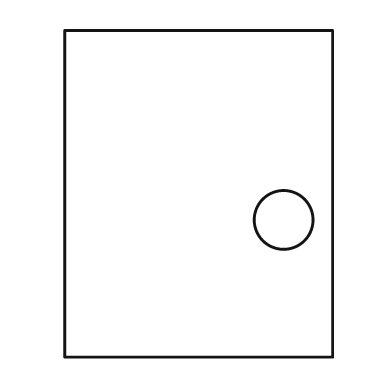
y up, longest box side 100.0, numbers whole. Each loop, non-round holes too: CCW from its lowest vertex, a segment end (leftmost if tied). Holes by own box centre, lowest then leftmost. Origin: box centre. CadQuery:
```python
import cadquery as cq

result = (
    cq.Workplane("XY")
    .moveTo(-41.0, -50.0)
    .lineTo(41.0, -50.0)
    .lineTo(41.0, 50.0)
    .lineTo(-41.0, 50.0)
    .close()
    .moveTo(26.0, -8.0)
    .circle(9.0)
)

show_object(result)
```